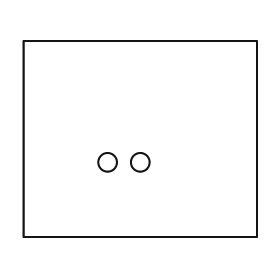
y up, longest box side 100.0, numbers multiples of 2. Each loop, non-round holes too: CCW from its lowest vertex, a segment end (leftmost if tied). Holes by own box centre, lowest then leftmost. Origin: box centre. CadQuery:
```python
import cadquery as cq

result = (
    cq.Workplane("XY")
    .moveTo(-50.0, -42.0)
    .lineTo(50.0, -42.0)
    .lineTo(50.0, 42.0)
    .lineTo(-50.0, 42.0)
    .close()
    .moveTo(-14.0, -10.0)
    .circle(4.0)
    .moveTo(0.0, -10.0)
    .circle(4.0)
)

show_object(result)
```